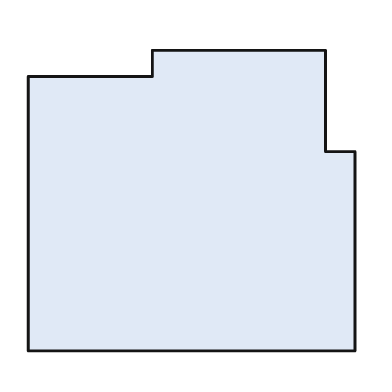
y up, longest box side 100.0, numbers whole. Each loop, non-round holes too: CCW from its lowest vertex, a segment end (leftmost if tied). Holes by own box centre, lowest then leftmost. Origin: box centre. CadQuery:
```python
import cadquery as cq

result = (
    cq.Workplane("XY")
    .moveTo(-50.0, -46.0)
    .lineTo(50.0, -46.0)
    .lineTo(50.0, 15.0)
    .lineTo(41.0, 15.0)
    .lineTo(41.0, 46.0)
    .lineTo(-12.0, 46.0)
    .lineTo(-12.0, 38.0)
    .lineTo(-50.0, 38.0)
    .close()
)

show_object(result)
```